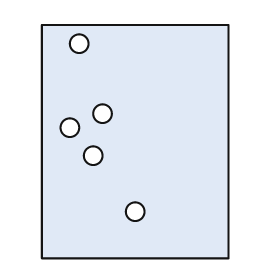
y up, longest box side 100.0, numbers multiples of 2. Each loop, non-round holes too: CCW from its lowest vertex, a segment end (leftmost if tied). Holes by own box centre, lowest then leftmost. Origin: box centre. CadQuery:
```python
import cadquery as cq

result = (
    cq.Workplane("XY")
    .moveTo(-40.0, -50.0)
    .lineTo(40.0, -50.0)
    .lineTo(40.0, 50.0)
    .lineTo(-40.0, 50.0)
    .close()
    .moveTo(0.0, -30.0)
    .circle(4.0)
    .moveTo(-18.0, -6.0)
    .circle(4.0)
    .moveTo(-28.0, 6.0)
    .circle(4.0)
    .moveTo(-14.0, 12.0)
    .circle(4.0)
    .moveTo(-24.0, 42.0)
    .circle(4.0)
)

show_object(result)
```